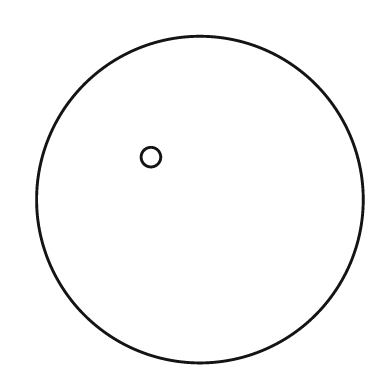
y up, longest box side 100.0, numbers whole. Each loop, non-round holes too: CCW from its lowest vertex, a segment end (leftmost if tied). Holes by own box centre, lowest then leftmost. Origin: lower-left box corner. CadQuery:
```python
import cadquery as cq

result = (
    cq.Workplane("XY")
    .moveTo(50.0, 50.0)
    .circle(50.0)
    .moveTo(35.0, 63.0)
    .circle(3.0)
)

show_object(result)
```